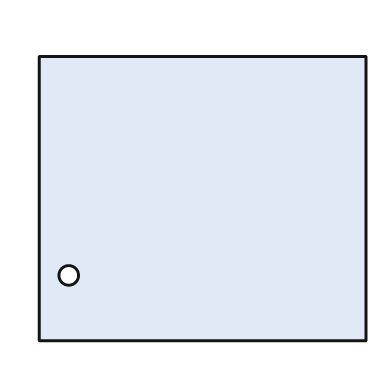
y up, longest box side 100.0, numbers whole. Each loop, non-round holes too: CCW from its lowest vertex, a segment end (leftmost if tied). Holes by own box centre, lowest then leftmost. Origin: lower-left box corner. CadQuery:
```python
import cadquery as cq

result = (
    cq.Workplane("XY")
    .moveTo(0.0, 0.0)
    .lineTo(100.0, 0.0)
    .lineTo(100.0, 87.0)
    .lineTo(0.0, 87.0)
    .close()
    .moveTo(9.0, 20.0)
    .circle(3.0)
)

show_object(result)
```